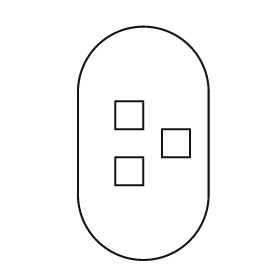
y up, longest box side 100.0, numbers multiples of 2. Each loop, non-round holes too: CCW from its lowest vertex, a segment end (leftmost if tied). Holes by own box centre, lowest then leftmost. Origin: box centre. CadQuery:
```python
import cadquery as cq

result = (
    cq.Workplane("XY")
    .moveTo(-28.0, -22.0)
    .threePointArc((0.0, -50.0), (28.0, -22.0))
    .lineTo(28.0, 22.0)
    .threePointArc((0.0, 50.0), (-28.0, 22.0))
    .close()
    .moveTo(-12.0, -18.0)
    .lineTo(0.0, -18.0)
    .lineTo(0.0, -6.0)
    .lineTo(-12.0, -6.0)
    .close()
    .moveTo(8.0, -6.0)
    .lineTo(20.0, -6.0)
    .lineTo(20.0, 6.0)
    .lineTo(8.0, 6.0)
    .close()
    .moveTo(-12.0, 6.0)
    .lineTo(0.0, 6.0)
    .lineTo(0.0, 18.0)
    .lineTo(-12.0, 18.0)
    .close()
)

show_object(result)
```